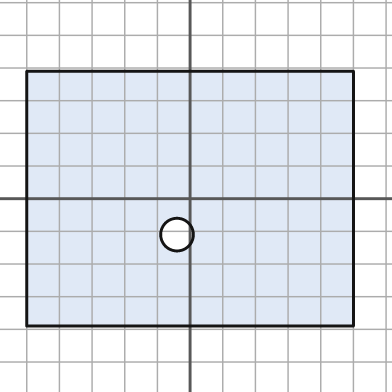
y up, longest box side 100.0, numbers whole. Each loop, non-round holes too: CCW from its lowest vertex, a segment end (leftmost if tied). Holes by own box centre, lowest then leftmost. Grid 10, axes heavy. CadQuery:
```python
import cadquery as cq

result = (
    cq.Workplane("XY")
    .moveTo(-50.0, -39.0)
    .lineTo(50.0, -39.0)
    .lineTo(50.0, 39.0)
    .lineTo(-50.0, 39.0)
    .close()
    .moveTo(-4.0, -11.0)
    .circle(5.0)
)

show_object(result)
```